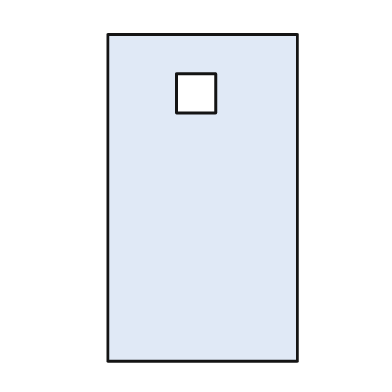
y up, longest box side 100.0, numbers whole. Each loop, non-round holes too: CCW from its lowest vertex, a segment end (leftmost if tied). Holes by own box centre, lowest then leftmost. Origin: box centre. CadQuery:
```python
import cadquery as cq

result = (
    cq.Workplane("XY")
    .moveTo(-29.0, -50.0)
    .lineTo(29.0, -50.0)
    .lineTo(29.0, 50.0)
    .lineTo(-29.0, 50.0)
    .close()
    .moveTo(-8.0, 26.0)
    .lineTo(4.0, 26.0)
    .lineTo(4.0, 38.0)
    .lineTo(-8.0, 38.0)
    .close()
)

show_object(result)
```